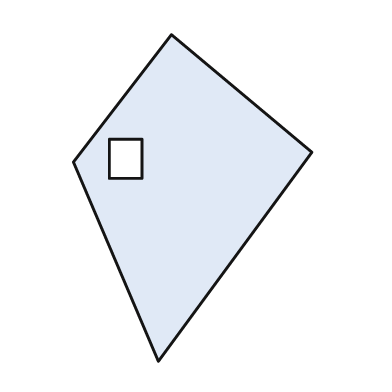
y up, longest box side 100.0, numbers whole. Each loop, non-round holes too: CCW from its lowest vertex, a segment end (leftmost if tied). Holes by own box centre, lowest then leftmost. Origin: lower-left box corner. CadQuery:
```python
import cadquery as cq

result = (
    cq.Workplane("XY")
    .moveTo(26.0, 0.0)
    .lineTo(73.0, 64.0)
    .lineTo(30.0, 100.0)
    .lineTo(0.0, 61.0)
    .close()
    .moveTo(11.0, 56.0)
    .lineTo(21.0, 56.0)
    .lineTo(21.0, 68.0)
    .lineTo(11.0, 68.0)
    .close()
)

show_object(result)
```